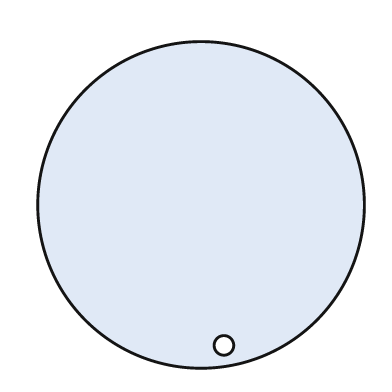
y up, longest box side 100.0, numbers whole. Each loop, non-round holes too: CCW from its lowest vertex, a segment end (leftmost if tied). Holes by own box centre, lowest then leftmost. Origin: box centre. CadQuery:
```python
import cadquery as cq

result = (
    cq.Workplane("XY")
    .moveTo(0.0, 0.0)
    .circle(50.0)
    .moveTo(7.0, -43.0)
    .circle(3.0)
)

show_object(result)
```